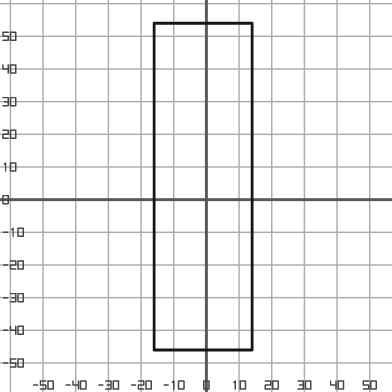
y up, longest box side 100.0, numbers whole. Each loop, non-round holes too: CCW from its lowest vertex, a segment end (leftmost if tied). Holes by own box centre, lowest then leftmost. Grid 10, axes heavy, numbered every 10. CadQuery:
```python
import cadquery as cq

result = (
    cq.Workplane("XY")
    .moveTo(-16.0, -46.0)
    .lineTo(14.0, -46.0)
    .lineTo(14.0, 54.0)
    .lineTo(-16.0, 54.0)
    .close()
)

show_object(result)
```